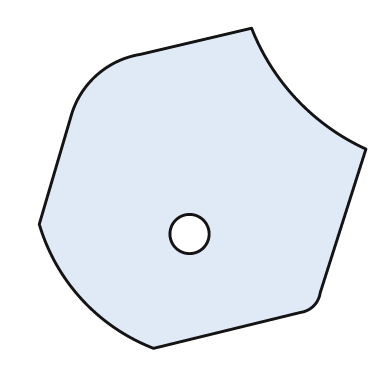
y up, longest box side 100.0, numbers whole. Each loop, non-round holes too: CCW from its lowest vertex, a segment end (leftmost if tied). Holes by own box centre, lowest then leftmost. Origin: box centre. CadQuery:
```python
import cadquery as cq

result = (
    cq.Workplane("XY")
    .moveTo(-15.0, -49.0)
    .lineTo(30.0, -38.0)
    .threePointArc((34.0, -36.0), (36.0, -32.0))
    .lineTo(50.0, 12.0)
    .threePointArc((29.0, 27.0), (15.0, 49.0))
    .lineTo(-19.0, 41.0)
    .threePointArc((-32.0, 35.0), (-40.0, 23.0))
    .lineTo(-50.0, -11.0)
    .threePointArc((-37.0, -34.0), (-15.0, -49.0))
    .close()
    .moveTo(-4.0, -14.0)
    .circle(6.0)
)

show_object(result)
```